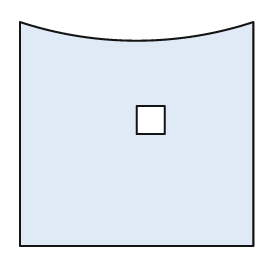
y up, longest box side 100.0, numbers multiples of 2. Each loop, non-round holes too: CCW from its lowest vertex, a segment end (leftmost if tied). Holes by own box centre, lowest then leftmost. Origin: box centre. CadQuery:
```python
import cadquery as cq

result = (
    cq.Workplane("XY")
    .moveTo(-50.0, -48.0)
    .lineTo(50.0, -48.0)
    .lineTo(50.0, 48.0)
    .threePointArc((0.0, 40.0), (-50.0, 48.0))
    .close()
    .moveTo(0.0, 0.0)
    .lineTo(12.0, 0.0)
    .lineTo(12.0, 12.0)
    .lineTo(0.0, 12.0)
    .close()
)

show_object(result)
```